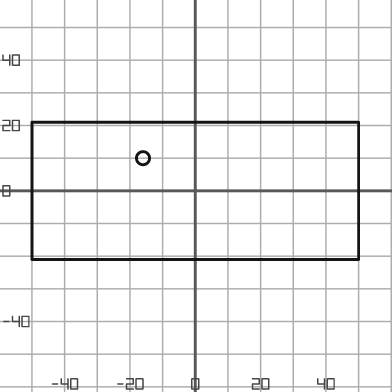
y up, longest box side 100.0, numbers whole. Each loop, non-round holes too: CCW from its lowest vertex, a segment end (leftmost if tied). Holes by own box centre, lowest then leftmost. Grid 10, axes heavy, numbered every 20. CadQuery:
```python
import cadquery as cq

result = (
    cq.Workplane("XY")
    .moveTo(-50.0, -21.0)
    .lineTo(50.0, -21.0)
    .lineTo(50.0, 21.0)
    .lineTo(-50.0, 21.0)
    .close()
    .moveTo(-16.0, 10.0)
    .circle(2.0)
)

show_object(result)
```